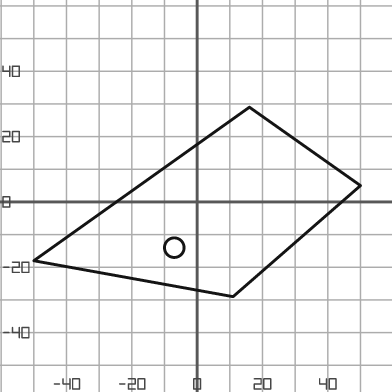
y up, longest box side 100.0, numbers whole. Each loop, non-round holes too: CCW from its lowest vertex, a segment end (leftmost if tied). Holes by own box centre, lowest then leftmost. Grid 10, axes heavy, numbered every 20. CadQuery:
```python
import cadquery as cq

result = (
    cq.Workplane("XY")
    .moveTo(11.0, -29.0)
    .lineTo(50.0, 5.0)
    .lineTo(16.0, 29.0)
    .lineTo(-50.0, -18.0)
    .close()
    .moveTo(-7.0, -14.0)
    .circle(3.0)
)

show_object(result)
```